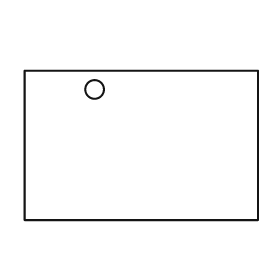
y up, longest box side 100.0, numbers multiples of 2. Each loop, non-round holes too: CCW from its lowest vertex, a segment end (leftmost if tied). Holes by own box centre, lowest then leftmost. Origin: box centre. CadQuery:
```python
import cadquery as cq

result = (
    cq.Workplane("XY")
    .moveTo(-50.0, -32.0)
    .lineTo(50.0, -32.0)
    .lineTo(50.0, 32.0)
    .lineTo(-50.0, 32.0)
    .close()
    .moveTo(-20.0, 24.0)
    .circle(4.0)
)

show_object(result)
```